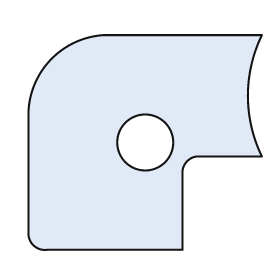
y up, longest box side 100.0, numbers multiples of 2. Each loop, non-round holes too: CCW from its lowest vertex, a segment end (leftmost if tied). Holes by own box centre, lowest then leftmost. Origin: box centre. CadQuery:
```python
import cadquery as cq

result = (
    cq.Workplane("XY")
    .moveTo(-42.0, -46.0)
    .lineTo(16.0, -46.0)
    .lineTo(16.0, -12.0)
    .threePointArc((18.0, -8.0), (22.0, -6.0))
    .lineTo(50.0, -6.0)
    .threePointArc((44.0, 20.0), (50.0, 46.0))
    .lineTo(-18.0, 46.0)
    .threePointArc((-40.0, 36.0), (-50.0, 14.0))
    .lineTo(-50.0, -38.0)
    .threePointArc((-48.0, -44.0), (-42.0, -46.0))
    .close()
    .moveTo(0.0, 0.0)
    .circle(12.0)
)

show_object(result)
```